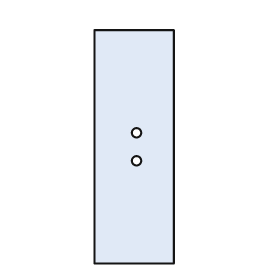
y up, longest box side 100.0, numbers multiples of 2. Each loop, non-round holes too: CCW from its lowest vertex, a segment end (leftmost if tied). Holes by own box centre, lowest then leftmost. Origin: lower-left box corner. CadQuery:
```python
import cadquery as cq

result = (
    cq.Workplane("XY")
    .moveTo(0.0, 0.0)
    .lineTo(34.0, 0.0)
    .lineTo(34.0, 100.0)
    .lineTo(0.0, 100.0)
    .close()
    .moveTo(18.0, 44.0)
    .circle(2.0)
    .moveTo(18.0, 56.0)
    .circle(2.0)
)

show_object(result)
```